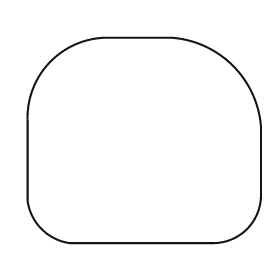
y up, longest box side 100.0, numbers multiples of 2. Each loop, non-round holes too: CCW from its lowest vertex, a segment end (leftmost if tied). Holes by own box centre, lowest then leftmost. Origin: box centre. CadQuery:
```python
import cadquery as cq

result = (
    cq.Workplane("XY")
    .moveTo(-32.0, -44.0)
    .lineTo(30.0, -44.0)
    .threePointArc((44.0, -38.0), (50.0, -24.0))
    .lineTo(50.0, 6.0)
    .threePointArc((38.0, 32.0), (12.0, 44.0))
    .lineTo(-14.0, 44.0)
    .threePointArc((-40.0, 34.0), (-50.0, 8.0))
    .lineTo(-50.0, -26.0)
    .threePointArc((-44.0, -38.0), (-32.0, -44.0))
    .close()
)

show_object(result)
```